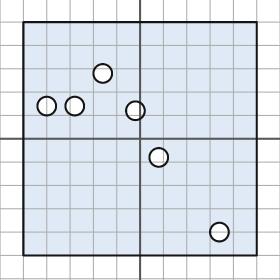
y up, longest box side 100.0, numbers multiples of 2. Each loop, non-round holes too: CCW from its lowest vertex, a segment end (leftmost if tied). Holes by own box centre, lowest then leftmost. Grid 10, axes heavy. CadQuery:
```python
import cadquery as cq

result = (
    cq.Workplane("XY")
    .moveTo(-50.0, -50.0)
    .lineTo(50.0, -50.0)
    .lineTo(50.0, 50.0)
    .lineTo(-50.0, 50.0)
    .close()
    .moveTo(34.0, -40.0)
    .circle(4.0)
    .moveTo(8.0, -8.0)
    .circle(4.0)
    .moveTo(-2.0, 12.0)
    .circle(4.0)
    .moveTo(-40.0, 14.0)
    .circle(4.0)
    .moveTo(-28.0, 14.0)
    .circle(4.0)
    .moveTo(-16.0, 28.0)
    .circle(4.0)
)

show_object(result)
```